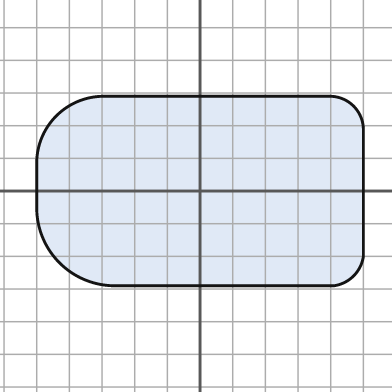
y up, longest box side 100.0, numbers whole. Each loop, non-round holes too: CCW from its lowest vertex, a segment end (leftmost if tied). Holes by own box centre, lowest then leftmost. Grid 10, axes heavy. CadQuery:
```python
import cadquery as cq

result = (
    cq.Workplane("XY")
    .moveTo(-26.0, -29.0)
    .lineTo(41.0, -29.0)
    .threePointArc((47.0, -26.0), (50.0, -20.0))
    .lineTo(50.0, 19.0)
    .threePointArc((47.0, 26.0), (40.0, 29.0))
    .lineTo(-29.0, 29.0)
    .threePointArc((-44.0, 23.0), (-50.0, 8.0))
    .lineTo(-50.0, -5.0)
    .threePointArc((-43.0, -22.0), (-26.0, -29.0))
    .close()
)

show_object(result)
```